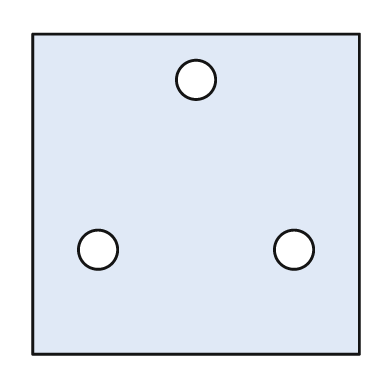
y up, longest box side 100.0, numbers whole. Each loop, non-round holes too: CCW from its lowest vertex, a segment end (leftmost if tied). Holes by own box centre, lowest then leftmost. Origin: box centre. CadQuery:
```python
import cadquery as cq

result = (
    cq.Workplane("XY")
    .moveTo(-50.0, -49.0)
    .lineTo(50.0, -49.0)
    .lineTo(50.0, 49.0)
    .lineTo(-50.0, 49.0)
    .close()
    .moveTo(-30.0, -17.0)
    .circle(6.0)
    .moveTo(30.0, -17.0)
    .circle(6.0)
    .moveTo(0.0, 35.0)
    .circle(6.0)
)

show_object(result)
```